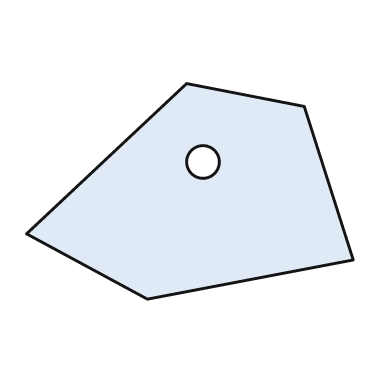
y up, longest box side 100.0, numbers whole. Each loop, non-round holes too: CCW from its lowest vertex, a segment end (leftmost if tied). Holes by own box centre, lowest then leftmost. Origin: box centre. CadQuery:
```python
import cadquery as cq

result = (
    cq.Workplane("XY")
    .moveTo(-13.0, -33.0)
    .lineTo(50.0, -21.0)
    .lineTo(35.0, 26.0)
    .lineTo(-1.0, 33.0)
    .lineTo(-50.0, -13.0)
    .close()
    .moveTo(4.0, 9.0)
    .circle(5.0)
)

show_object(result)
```